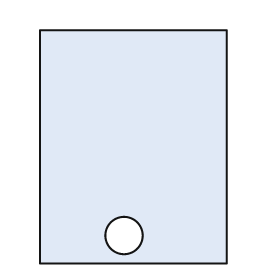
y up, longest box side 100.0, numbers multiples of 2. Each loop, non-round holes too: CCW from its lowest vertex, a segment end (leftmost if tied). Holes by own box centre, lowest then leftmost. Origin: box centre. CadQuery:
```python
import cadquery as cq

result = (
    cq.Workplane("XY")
    .moveTo(-40.0, -50.0)
    .lineTo(40.0, -50.0)
    .lineTo(40.0, 50.0)
    .lineTo(-40.0, 50.0)
    .close()
    .moveTo(-4.0, -38.0)
    .circle(8.0)
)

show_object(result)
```